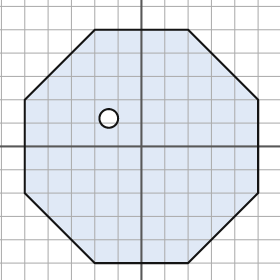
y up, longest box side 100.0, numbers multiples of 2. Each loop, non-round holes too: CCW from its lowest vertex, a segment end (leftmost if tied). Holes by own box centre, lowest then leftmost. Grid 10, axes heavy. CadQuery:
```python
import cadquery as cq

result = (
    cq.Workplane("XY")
    .moveTo(-20.0, -50.0)
    .lineTo(20.0, -50.0)
    .lineTo(50.0, -20.0)
    .lineTo(50.0, 20.0)
    .lineTo(20.0, 50.0)
    .lineTo(-20.0, 50.0)
    .lineTo(-50.0, 20.0)
    .lineTo(-50.0, -20.0)
    .close()
    .moveTo(-14.0, 12.0)
    .circle(4.0)
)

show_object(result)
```